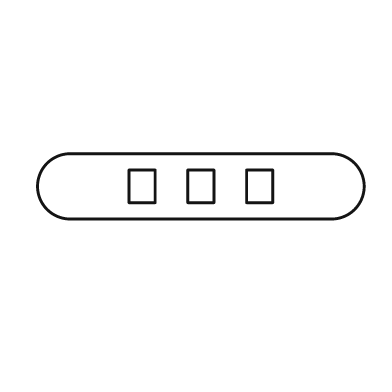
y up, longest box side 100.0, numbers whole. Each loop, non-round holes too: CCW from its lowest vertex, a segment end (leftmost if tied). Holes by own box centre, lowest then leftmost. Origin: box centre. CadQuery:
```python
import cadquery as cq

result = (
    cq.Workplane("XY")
    .moveTo(-40.0, -10.0)
    .lineTo(40.0, -10.0)
    .threePointArc((50.0, 0.0), (40.0, 10.0))
    .lineTo(-40.0, 10.0)
    .threePointArc((-50.0, 0.0), (-40.0, -10.0))
    .close()
    .moveTo(-22.0, -5.0)
    .lineTo(-14.0, -5.0)
    .lineTo(-14.0, 5.0)
    .lineTo(-22.0, 5.0)
    .close()
    .moveTo(-4.0, -5.0)
    .lineTo(4.0, -5.0)
    .lineTo(4.0, 5.0)
    .lineTo(-4.0, 5.0)
    .close()
    .moveTo(14.0, -5.0)
    .lineTo(22.0, -5.0)
    .lineTo(22.0, 5.0)
    .lineTo(14.0, 5.0)
    .close()
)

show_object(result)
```